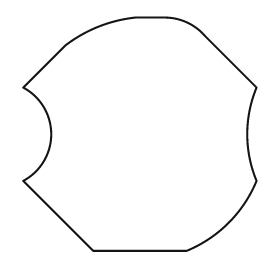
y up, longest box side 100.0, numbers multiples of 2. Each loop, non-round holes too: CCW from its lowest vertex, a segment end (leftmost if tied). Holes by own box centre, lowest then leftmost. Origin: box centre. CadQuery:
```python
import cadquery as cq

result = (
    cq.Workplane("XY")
    .moveTo(-20.0, -50.0)
    .lineTo(20.0, -50.0)
    .threePointArc((38.0, -38.0), (50.0, -20.0))
    .threePointArc((46.0, 0.0), (50.0, 20.0))
    .lineTo(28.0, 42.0)
    .threePointArc((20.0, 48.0), (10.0, 50.0))
    .lineTo(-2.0, 50.0)
    .threePointArc((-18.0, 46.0), (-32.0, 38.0))
    .lineTo(-50.0, 20.0)
    .threePointArc((-38.0, 0.0), (-50.0, -20.0))
    .close()
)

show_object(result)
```